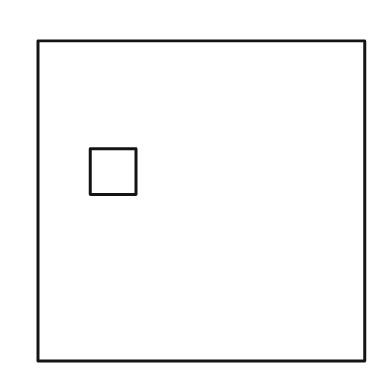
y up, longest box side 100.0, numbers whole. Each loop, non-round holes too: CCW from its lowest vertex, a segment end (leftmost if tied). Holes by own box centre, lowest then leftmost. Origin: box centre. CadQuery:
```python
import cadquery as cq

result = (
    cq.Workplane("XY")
    .moveTo(-50.0, -49.0)
    .lineTo(50.0, -49.0)
    .lineTo(50.0, 49.0)
    .lineTo(-50.0, 49.0)
    .close()
    .moveTo(-34.0, 2.0)
    .lineTo(-20.0, 2.0)
    .lineTo(-20.0, 16.0)
    .lineTo(-34.0, 16.0)
    .close()
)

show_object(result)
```